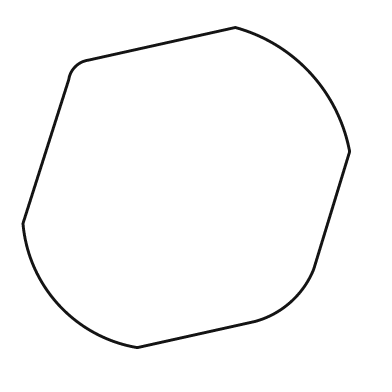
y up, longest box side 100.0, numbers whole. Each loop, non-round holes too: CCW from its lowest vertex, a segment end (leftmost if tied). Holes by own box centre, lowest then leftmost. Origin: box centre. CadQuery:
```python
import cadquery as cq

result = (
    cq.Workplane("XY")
    .moveTo(-15.0, -49.0)
    .lineTo(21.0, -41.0)
    .threePointArc((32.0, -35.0), (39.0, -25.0))
    .lineTo(50.0, 11.0)
    .threePointArc((38.0, 35.0), (15.0, 49.0))
    .lineTo(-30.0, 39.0)
    .threePointArc((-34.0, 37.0), (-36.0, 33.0))
    .lineTo(-50.0, -11.0)
    .threePointArc((-39.0, -36.0), (-15.0, -49.0))
    .close()
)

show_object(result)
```